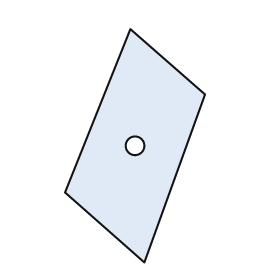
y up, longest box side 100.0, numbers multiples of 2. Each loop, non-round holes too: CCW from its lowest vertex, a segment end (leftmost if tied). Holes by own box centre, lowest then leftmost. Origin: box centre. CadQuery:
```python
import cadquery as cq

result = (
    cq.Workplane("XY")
    .moveTo(4.0, -50.0)
    .lineTo(30.0, 22.0)
    .lineTo(-2.0, 50.0)
    .lineTo(-30.0, -20.0)
    .close()
    .moveTo(0.0, 0.0)
    .circle(4.0)
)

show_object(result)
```